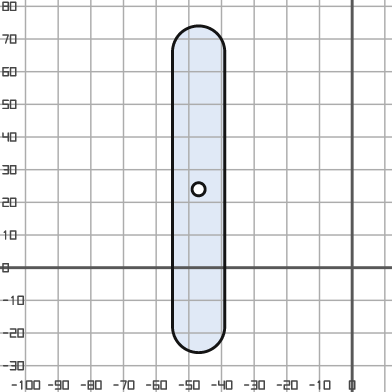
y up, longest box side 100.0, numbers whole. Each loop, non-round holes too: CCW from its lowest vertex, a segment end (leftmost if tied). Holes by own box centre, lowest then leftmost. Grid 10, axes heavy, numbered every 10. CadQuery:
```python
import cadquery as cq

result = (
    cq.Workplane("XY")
    .moveTo(-55.0, -18.0)
    .threePointArc((-47.0, -26.0), (-39.0, -18.0))
    .lineTo(-39.0, 66.0)
    .threePointArc((-47.0, 74.0), (-55.0, 66.0))
    .close()
    .moveTo(-47.0, 24.0)
    .circle(2.0)
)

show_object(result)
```